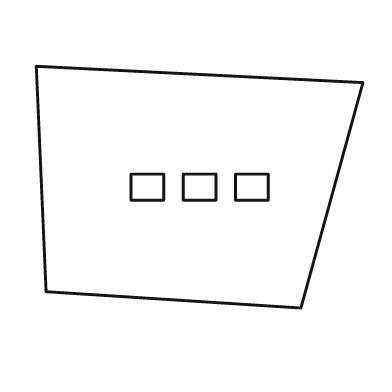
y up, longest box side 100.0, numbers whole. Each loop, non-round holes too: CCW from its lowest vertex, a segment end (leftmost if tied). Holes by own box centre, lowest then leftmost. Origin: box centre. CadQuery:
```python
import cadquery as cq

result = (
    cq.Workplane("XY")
    .moveTo(31.0, -37.0)
    .lineTo(50.0, 32.0)
    .lineTo(-50.0, 37.0)
    .lineTo(-47.0, -32.0)
    .close()
    .moveTo(-21.0, -4.0)
    .lineTo(-11.0, -4.0)
    .lineTo(-11.0, 4.0)
    .lineTo(-21.0, 4.0)
    .close()
    .moveTo(-5.0, -4.0)
    .lineTo(5.0, -4.0)
    .lineTo(5.0, 4.0)
    .lineTo(-5.0, 4.0)
    .close()
    .moveTo(11.0, -4.0)
    .lineTo(21.0, -4.0)
    .lineTo(21.0, 4.0)
    .lineTo(11.0, 4.0)
    .close()
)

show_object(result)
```